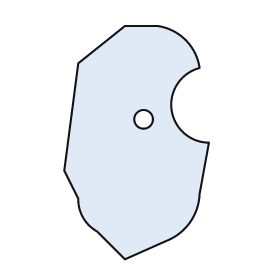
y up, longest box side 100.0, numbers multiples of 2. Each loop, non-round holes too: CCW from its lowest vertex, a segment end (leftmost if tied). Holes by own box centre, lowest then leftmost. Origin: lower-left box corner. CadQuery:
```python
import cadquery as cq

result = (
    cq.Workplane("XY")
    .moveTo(26.0, 0.0)
    .lineTo(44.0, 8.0)
    .threePointArc((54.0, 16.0), (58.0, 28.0))
    .lineTo(62.0, 50.0)
    .threePointArc((46.0, 64.0), (58.0, 82.0))
    .threePointArc((52.0, 94.0), (40.0, 100.0))
    .lineTo(26.0, 100.0)
    .lineTo(6.0, 84.0)
    .lineTo(0.0, 38.0)
    .lineTo(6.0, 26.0)
    .threePointArc((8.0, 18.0), (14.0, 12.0))
    .close()
    .moveTo(34.0, 60.0)
    .circle(4.0)
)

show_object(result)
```